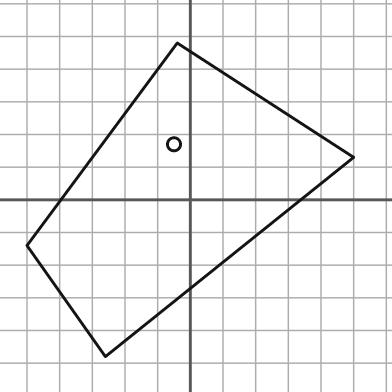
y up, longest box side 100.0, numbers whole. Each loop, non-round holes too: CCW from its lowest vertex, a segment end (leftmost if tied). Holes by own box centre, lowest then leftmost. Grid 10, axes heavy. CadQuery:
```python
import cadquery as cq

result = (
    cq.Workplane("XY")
    .moveTo(-26.0, -48.0)
    .lineTo(50.0, 13.0)
    .lineTo(-4.0, 48.0)
    .lineTo(-50.0, -14.0)
    .close()
    .moveTo(-5.0, 17.0)
    .circle(2.0)
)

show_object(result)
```